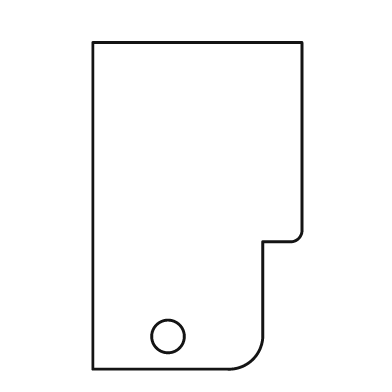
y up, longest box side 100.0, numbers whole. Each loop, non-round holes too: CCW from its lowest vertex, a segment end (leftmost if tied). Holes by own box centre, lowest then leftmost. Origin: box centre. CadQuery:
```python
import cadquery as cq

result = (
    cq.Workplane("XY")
    .moveTo(-32.0, -50.0)
    .lineTo(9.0, -50.0)
    .threePointArc((17.0, -47.0), (20.0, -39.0))
    .lineTo(20.0, -11.0)
    .lineTo(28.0, -11.0)
    .threePointArc((31.0, -10.0), (32.0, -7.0))
    .lineTo(32.0, 50.0)
    .lineTo(-32.0, 50.0)
    .close()
    .moveTo(-9.0, -40.0)
    .circle(5.0)
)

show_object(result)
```